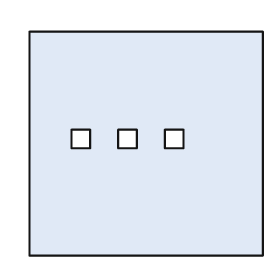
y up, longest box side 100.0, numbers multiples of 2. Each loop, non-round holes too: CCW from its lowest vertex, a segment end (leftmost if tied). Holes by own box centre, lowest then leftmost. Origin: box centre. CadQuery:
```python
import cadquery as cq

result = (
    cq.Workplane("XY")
    .moveTo(-50.0, -48.0)
    .lineTo(50.0, -48.0)
    .lineTo(50.0, 48.0)
    .lineTo(-50.0, 48.0)
    .close()
    .moveTo(-32.0, -2.0)
    .lineTo(-24.0, -2.0)
    .lineTo(-24.0, 6.0)
    .lineTo(-32.0, 6.0)
    .close()
    .moveTo(-12.0, -2.0)
    .lineTo(-4.0, -2.0)
    .lineTo(-4.0, 6.0)
    .lineTo(-12.0, 6.0)
    .close()
    .moveTo(8.0, -2.0)
    .lineTo(16.0, -2.0)
    .lineTo(16.0, 6.0)
    .lineTo(8.0, 6.0)
    .close()
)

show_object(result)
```